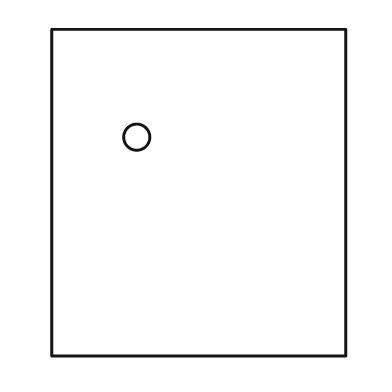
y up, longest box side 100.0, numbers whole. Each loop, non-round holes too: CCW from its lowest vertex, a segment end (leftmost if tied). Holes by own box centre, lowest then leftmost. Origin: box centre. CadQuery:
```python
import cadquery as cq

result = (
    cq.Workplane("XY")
    .moveTo(-45.0, -50.0)
    .lineTo(45.0, -50.0)
    .lineTo(45.0, 50.0)
    .lineTo(-45.0, 50.0)
    .close()
    .moveTo(-19.0, 17.0)
    .circle(4.0)
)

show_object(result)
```